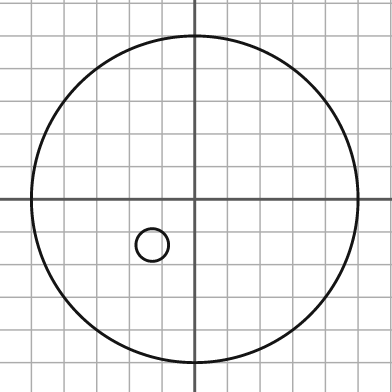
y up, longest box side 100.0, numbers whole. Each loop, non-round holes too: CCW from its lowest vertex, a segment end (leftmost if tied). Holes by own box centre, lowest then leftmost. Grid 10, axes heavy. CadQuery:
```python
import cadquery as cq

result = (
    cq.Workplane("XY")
    .moveTo(0.0, 0.0)
    .circle(50.0)
    .moveTo(-13.0, -14.0)
    .circle(5.0)
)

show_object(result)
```